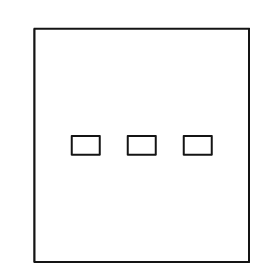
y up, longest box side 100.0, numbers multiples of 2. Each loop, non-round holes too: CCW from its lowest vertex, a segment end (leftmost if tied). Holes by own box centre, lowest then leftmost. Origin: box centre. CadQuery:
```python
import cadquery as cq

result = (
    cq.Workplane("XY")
    .moveTo(-46.0, -50.0)
    .lineTo(46.0, -50.0)
    .lineTo(46.0, 50.0)
    .lineTo(-46.0, 50.0)
    .close()
    .moveTo(-30.0, -4.0)
    .lineTo(-18.0, -4.0)
    .lineTo(-18.0, 4.0)
    .lineTo(-30.0, 4.0)
    .close()
    .moveTo(-6.0, -4.0)
    .lineTo(6.0, -4.0)
    .lineTo(6.0, 4.0)
    .lineTo(-6.0, 4.0)
    .close()
    .moveTo(18.0, -4.0)
    .lineTo(30.0, -4.0)
    .lineTo(30.0, 4.0)
    .lineTo(18.0, 4.0)
    .close()
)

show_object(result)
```